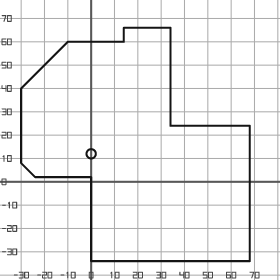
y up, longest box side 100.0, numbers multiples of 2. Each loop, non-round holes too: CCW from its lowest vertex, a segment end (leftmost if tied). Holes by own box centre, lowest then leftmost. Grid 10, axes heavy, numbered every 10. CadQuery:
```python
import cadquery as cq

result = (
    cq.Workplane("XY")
    .moveTo(0.0, -34.0)
    .lineTo(68.0, -34.0)
    .lineTo(68.0, 24.0)
    .lineTo(34.0, 24.0)
    .lineTo(34.0, 66.0)
    .lineTo(14.0, 66.0)
    .lineTo(14.0, 60.0)
    .lineTo(-10.0, 60.0)
    .lineTo(-30.0, 40.0)
    .lineTo(-30.0, 8.0)
    .lineTo(-24.0, 2.0)
    .lineTo(0.0, 2.0)
    .close()
    .moveTo(0.0, 12.0)
    .circle(2.0)
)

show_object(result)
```